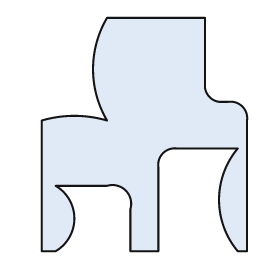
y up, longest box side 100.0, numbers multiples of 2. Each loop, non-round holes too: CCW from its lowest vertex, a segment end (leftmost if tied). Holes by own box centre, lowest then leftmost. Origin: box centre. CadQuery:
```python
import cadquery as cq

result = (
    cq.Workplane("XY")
    .moveTo(-44.0, -50.0)
    .lineTo(-38.0, -50.0)
    .threePointArc((-30.0, -36.0), (-38.0, -22.0))
    .lineTo(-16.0, -22.0)
    .threePointArc((-8.0, -24.0), (-6.0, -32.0))
    .lineTo(-6.0, -50.0)
    .lineTo(6.0, -50.0)
    .lineTo(6.0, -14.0)
    .threePointArc((8.0, -8.0), (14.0, -6.0))
    .lineTo(40.0, -6.0)
    .threePointArc((32.0, -28.0), (40.0, -50.0))
    .lineTo(44.0, -50.0)
    .lineTo(44.0, 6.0)
    .threePointArc((42.0, 12.0), (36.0, 14.0))
    .lineTo(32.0, 14.0)
    .threePointArc((28.0, 16.0), (26.0, 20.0))
    .lineTo(26.0, 50.0)
    .lineTo(-16.0, 50.0)
    .threePointArc((-22.0, 28.0), (-16.0, 6.0))
    .threePointArc((-30.0, 8.0), (-44.0, 6.0))
    .close()
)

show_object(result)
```